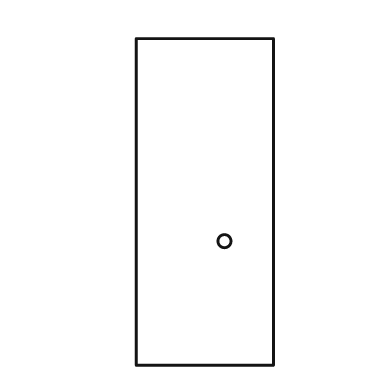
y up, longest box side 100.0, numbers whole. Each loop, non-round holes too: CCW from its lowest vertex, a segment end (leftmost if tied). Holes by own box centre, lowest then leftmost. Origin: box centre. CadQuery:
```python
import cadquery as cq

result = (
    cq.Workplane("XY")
    .moveTo(-21.0, -50.0)
    .lineTo(21.0, -50.0)
    .lineTo(21.0, 50.0)
    .lineTo(-21.0, 50.0)
    .close()
    .moveTo(6.0, -12.0)
    .circle(2.0)
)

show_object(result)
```